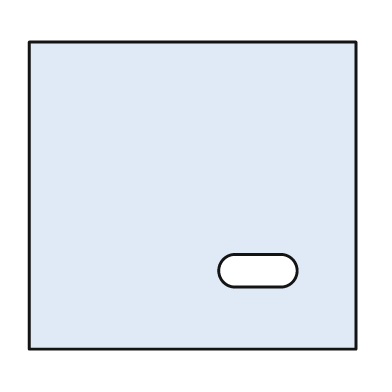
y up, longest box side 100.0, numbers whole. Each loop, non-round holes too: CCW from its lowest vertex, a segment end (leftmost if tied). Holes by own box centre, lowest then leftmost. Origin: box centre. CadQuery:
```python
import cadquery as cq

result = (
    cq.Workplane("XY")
    .moveTo(-50.0, -47.0)
    .lineTo(50.0, -47.0)
    .lineTo(50.0, 47.0)
    .lineTo(-50.0, 47.0)
    .close()
    .moveTo(13.0, -28.0)
    .lineTo(27.0, -28.0)
    .threePointArc((32.0, -23.0), (27.0, -18.0))
    .lineTo(13.0, -18.0)
    .threePointArc((8.0, -23.0), (13.0, -28.0))
    .close()
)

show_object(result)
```